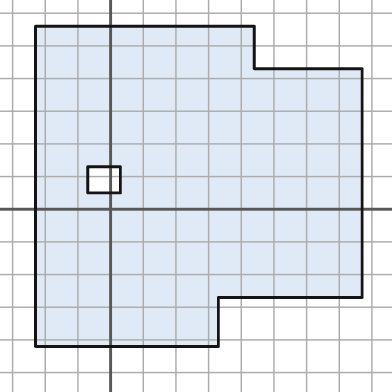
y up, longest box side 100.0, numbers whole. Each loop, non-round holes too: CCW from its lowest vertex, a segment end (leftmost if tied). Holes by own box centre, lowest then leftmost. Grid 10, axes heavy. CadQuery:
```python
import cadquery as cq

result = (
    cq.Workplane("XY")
    .moveTo(-23.0, -42.0)
    .lineTo(33.0, -42.0)
    .lineTo(33.0, -27.0)
    .lineTo(77.0, -27.0)
    .lineTo(77.0, 43.0)
    .lineTo(44.0, 43.0)
    .lineTo(44.0, 56.0)
    .lineTo(-23.0, 56.0)
    .close()
    .moveTo(-7.0, 5.0)
    .lineTo(3.0, 5.0)
    .lineTo(3.0, 13.0)
    .lineTo(-7.0, 13.0)
    .close()
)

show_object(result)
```